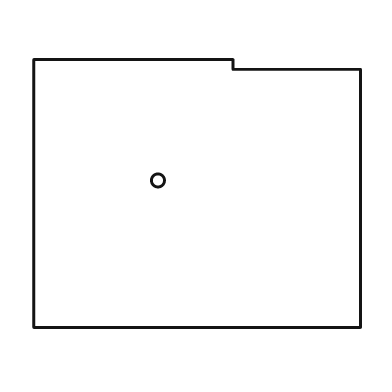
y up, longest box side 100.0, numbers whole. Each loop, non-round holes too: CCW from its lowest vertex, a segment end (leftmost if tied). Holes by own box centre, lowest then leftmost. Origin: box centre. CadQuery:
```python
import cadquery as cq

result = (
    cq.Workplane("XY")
    .moveTo(-50.0, -41.0)
    .lineTo(50.0, -41.0)
    .lineTo(50.0, 38.0)
    .lineTo(11.0, 38.0)
    .lineTo(11.0, 41.0)
    .lineTo(-50.0, 41.0)
    .close()
    .moveTo(-12.0, 4.0)
    .circle(2.0)
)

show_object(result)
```